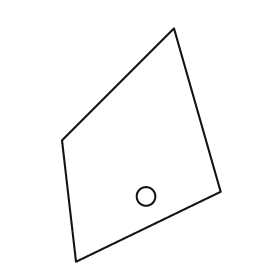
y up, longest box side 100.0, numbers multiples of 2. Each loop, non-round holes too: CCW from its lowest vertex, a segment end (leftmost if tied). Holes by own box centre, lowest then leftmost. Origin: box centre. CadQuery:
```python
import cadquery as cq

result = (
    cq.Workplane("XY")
    .moveTo(-28.0, -50.0)
    .lineTo(34.0, -20.0)
    .lineTo(14.0, 50.0)
    .lineTo(-34.0, 2.0)
    .close()
    .moveTo(2.0, -22.0)
    .circle(4.0)
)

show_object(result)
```